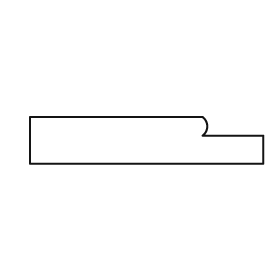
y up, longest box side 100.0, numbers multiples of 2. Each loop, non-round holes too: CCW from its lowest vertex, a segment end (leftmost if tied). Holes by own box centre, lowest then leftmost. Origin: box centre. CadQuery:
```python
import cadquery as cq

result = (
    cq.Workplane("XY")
    .moveTo(-50.0, -10.0)
    .lineTo(50.0, -10.0)
    .lineTo(50.0, 2.0)
    .lineTo(24.0, 2.0)
    .threePointArc((26.0, 6.0), (24.0, 10.0))
    .lineTo(-50.0, 10.0)
    .close()
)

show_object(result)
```